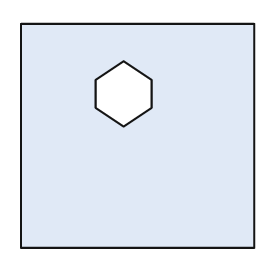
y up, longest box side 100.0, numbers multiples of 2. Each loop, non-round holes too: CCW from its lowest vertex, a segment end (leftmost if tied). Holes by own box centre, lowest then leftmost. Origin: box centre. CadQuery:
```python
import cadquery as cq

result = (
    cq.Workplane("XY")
    .moveTo(-50.0, -48.0)
    .lineTo(50.0, -48.0)
    .lineTo(50.0, 48.0)
    .lineTo(-50.0, 48.0)
    .close()
    .moveTo(-6.0, 4.0)
    .lineTo(6.0, 12.0)
    .lineTo(6.0, 24.0)
    .lineTo(-6.0, 32.0)
    .lineTo(-18.0, 24.0)
    .lineTo(-18.0, 12.0)
    .close()
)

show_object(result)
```